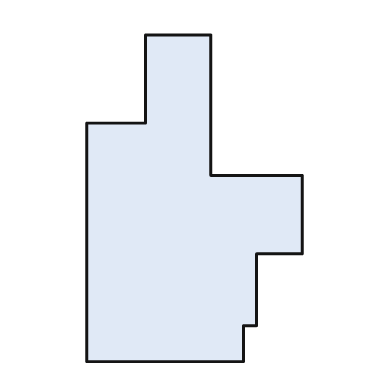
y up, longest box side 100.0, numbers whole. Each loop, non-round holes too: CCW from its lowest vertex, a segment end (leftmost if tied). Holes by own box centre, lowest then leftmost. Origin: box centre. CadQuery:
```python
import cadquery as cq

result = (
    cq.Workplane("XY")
    .moveTo(-33.0, -50.0)
    .lineTo(15.0, -50.0)
    .lineTo(15.0, -39.0)
    .lineTo(19.0, -39.0)
    .lineTo(19.0, -17.0)
    .lineTo(33.0, -17.0)
    .lineTo(33.0, 7.0)
    .lineTo(5.0, 7.0)
    .lineTo(5.0, 50.0)
    .lineTo(-15.0, 50.0)
    .lineTo(-15.0, 23.0)
    .lineTo(-33.0, 23.0)
    .close()
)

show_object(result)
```